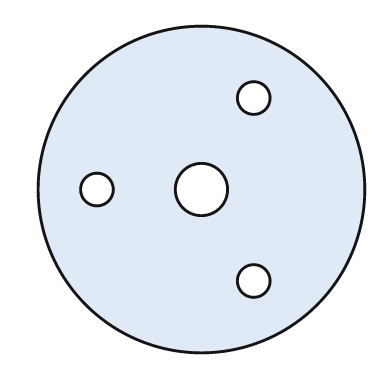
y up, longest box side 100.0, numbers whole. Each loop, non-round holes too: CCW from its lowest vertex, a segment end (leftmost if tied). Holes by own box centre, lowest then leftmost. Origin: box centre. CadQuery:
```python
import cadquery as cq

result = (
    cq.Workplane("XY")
    .moveTo(0.0, 0.0)
    .circle(50.0)
    .moveTo(16.0, -28.0)
    .circle(5.0)
    .moveTo(-32.0, 0.0)
    .circle(5.0)
    .moveTo(0.0, 0.0)
    .circle(8.0)
    .moveTo(16.0, 28.0)
    .circle(5.0)
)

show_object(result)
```